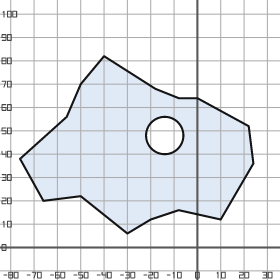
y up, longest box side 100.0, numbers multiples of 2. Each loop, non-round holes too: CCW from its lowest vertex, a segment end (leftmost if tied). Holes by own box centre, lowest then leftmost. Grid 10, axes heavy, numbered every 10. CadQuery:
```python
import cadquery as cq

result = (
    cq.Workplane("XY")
    .moveTo(-30.0, 6.0)
    .lineTo(-20.0, 12.0)
    .lineTo(-8.0, 16.0)
    .lineTo(10.0, 12.0)
    .lineTo(24.0, 36.0)
    .lineTo(22.0, 52.0)
    .lineTo(0.0, 64.0)
    .lineTo(-8.0, 64.0)
    .lineTo(-18.0, 68.0)
    .lineTo(-40.0, 82.0)
    .lineTo(-50.0, 70.0)
    .lineTo(-56.0, 56.0)
    .lineTo(-76.0, 38.0)
    .lineTo(-66.0, 20.0)
    .lineTo(-50.0, 22.0)
    .close()
    .moveTo(-14.0, 48.0)
    .circle(8.0)
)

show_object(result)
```